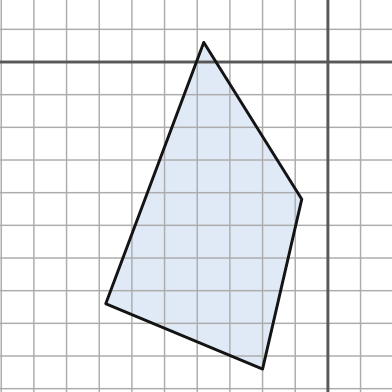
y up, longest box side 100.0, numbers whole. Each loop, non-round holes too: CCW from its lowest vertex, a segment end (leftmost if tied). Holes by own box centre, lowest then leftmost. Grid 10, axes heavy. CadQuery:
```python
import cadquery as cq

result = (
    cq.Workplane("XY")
    .moveTo(-20.0, -94.0)
    .lineTo(-8.0, -42.0)
    .lineTo(-38.0, 6.0)
    .lineTo(-68.0, -74.0)
    .close()
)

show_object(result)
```